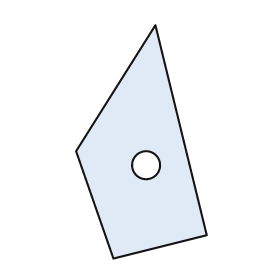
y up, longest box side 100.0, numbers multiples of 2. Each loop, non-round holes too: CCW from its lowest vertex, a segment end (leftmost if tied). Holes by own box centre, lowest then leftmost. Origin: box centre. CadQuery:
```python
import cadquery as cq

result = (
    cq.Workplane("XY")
    .moveTo(-12.0, -50.0)
    .lineTo(28.0, -40.0)
    .lineTo(6.0, 50.0)
    .lineTo(-28.0, -4.0)
    .close()
    .moveTo(2.0, -10.0)
    .circle(6.0)
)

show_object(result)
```